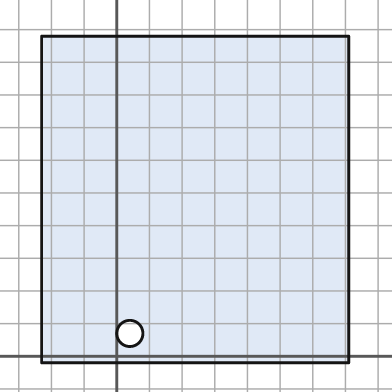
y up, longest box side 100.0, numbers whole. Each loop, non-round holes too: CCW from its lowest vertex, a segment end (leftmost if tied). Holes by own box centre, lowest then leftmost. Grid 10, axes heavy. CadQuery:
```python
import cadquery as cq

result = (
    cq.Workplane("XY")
    .moveTo(-23.0, -2.0)
    .lineTo(71.0, -2.0)
    .lineTo(71.0, 98.0)
    .lineTo(-23.0, 98.0)
    .close()
    .moveTo(4.0, 7.0)
    .circle(4.0)
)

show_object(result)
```